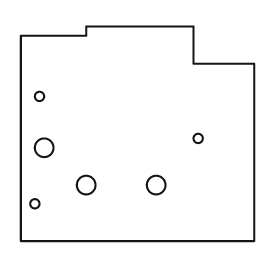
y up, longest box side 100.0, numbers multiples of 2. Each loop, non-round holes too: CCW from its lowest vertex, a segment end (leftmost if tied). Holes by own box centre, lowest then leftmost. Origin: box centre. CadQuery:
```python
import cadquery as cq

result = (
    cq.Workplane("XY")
    .moveTo(-50.0, -46.0)
    .lineTo(50.0, -46.0)
    .lineTo(50.0, 30.0)
    .lineTo(24.0, 30.0)
    .lineTo(24.0, 46.0)
    .lineTo(-22.0, 46.0)
    .lineTo(-22.0, 42.0)
    .lineTo(-50.0, 42.0)
    .close()
    .moveTo(-44.0, -30.0)
    .circle(2.0)
    .moveTo(-22.0, -22.0)
    .circle(4.0)
    .moveTo(8.0, -22.0)
    .circle(4.0)
    .moveTo(-40.0, -6.0)
    .circle(4.0)
    .moveTo(26.0, -2.0)
    .circle(2.0)
    .moveTo(-42.0, 16.0)
    .circle(2.0)
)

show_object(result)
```